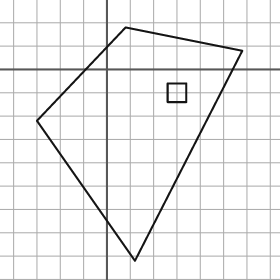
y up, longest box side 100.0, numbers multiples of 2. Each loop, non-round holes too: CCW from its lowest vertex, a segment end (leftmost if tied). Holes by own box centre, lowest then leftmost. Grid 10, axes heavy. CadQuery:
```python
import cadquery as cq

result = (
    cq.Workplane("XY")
    .moveTo(12.0, -82.0)
    .lineTo(58.0, 8.0)
    .lineTo(8.0, 18.0)
    .lineTo(-30.0, -22.0)
    .close()
    .moveTo(26.0, -14.0)
    .lineTo(34.0, -14.0)
    .lineTo(34.0, -6.0)
    .lineTo(26.0, -6.0)
    .close()
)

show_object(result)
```